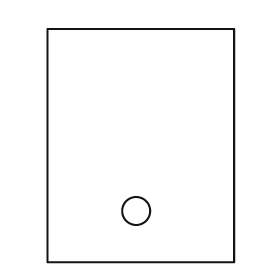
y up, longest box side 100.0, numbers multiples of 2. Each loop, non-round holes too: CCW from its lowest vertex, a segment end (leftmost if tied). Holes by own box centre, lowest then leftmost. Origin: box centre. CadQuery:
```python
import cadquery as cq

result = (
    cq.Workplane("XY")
    .moveTo(-40.0, -50.0)
    .lineTo(40.0, -50.0)
    .lineTo(40.0, 50.0)
    .lineTo(-40.0, 50.0)
    .close()
    .moveTo(-2.0, -28.0)
    .circle(6.0)
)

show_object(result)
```